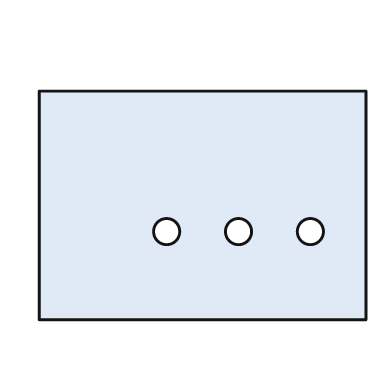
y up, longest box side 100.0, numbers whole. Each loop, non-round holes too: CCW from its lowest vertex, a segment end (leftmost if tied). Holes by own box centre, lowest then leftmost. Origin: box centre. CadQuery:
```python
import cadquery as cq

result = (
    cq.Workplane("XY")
    .moveTo(-50.0, -35.0)
    .lineTo(50.0, -35.0)
    .lineTo(50.0, 35.0)
    .lineTo(-50.0, 35.0)
    .close()
    .moveTo(-11.0, -8.0)
    .circle(4.0)
    .moveTo(11.0, -8.0)
    .circle(4.0)
    .moveTo(33.0, -8.0)
    .circle(4.0)
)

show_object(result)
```